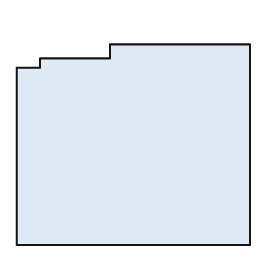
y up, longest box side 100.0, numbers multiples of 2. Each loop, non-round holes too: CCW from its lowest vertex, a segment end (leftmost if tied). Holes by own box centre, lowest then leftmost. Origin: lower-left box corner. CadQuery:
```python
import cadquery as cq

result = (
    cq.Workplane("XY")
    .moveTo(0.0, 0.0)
    .lineTo(100.0, 0.0)
    .lineTo(100.0, 86.0)
    .lineTo(40.0, 86.0)
    .lineTo(40.0, 80.0)
    .lineTo(10.0, 80.0)
    .lineTo(10.0, 76.0)
    .lineTo(0.0, 76.0)
    .close()
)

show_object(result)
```